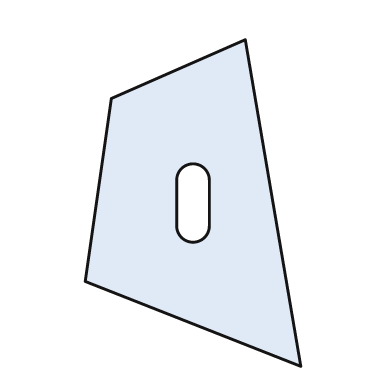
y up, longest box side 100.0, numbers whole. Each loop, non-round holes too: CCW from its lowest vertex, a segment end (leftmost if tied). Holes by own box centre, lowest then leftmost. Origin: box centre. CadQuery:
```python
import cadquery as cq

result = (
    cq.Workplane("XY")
    .moveTo(33.0, -50.0)
    .lineTo(16.0, 50.0)
    .lineTo(-25.0, 32.0)
    .lineTo(-33.0, -24.0)
    .close()
    .moveTo(-5.0, -7.0)
    .threePointArc((0.0, -12.0), (5.0, -7.0))
    .lineTo(5.0, 7.0)
    .threePointArc((0.0, 12.0), (-5.0, 7.0))
    .close()
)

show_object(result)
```